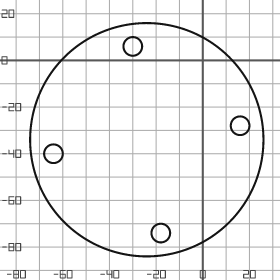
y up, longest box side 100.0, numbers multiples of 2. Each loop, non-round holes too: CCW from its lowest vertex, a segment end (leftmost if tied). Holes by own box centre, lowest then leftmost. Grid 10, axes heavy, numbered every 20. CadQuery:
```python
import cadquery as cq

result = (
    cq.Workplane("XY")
    .moveTo(-24.0, -34.0)
    .circle(50.0)
    .moveTo(-18.0, -74.0)
    .circle(4.0)
    .moveTo(-64.0, -40.0)
    .circle(4.0)
    .moveTo(16.0, -28.0)
    .circle(4.0)
    .moveTo(-30.0, 6.0)
    .circle(4.0)
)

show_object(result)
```